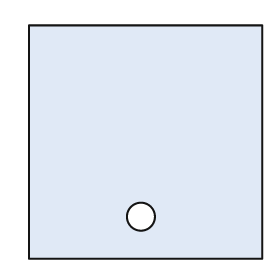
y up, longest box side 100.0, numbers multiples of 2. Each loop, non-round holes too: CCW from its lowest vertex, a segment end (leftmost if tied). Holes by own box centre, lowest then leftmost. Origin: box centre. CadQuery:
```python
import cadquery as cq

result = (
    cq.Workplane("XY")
    .moveTo(-50.0, -50.0)
    .lineTo(50.0, -50.0)
    .lineTo(50.0, 50.0)
    .lineTo(-50.0, 50.0)
    .close()
    .moveTo(-2.0, -32.0)
    .circle(6.0)
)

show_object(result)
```